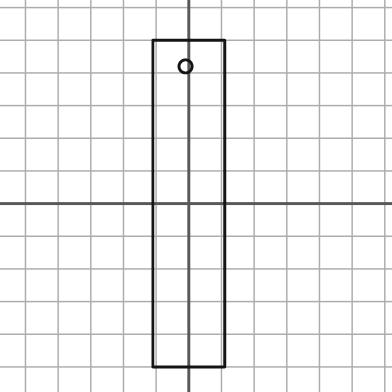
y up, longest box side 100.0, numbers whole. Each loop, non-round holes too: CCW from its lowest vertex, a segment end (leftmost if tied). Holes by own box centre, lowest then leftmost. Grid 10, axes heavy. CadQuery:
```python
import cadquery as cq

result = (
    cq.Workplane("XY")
    .moveTo(-11.0, -50.0)
    .lineTo(11.0, -50.0)
    .lineTo(11.0, 50.0)
    .lineTo(-11.0, 50.0)
    .close()
    .moveTo(-1.0, 42.0)
    .circle(2.0)
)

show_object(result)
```